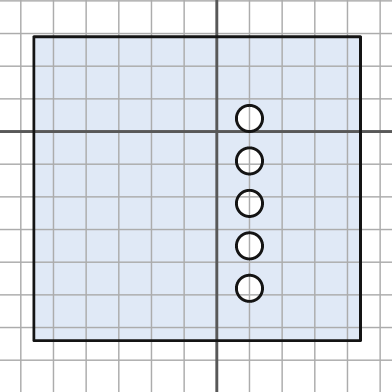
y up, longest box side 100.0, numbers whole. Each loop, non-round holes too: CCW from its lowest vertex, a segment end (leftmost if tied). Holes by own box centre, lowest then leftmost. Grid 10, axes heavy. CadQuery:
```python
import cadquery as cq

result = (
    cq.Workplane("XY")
    .moveTo(-56.0, -64.0)
    .lineTo(44.0, -64.0)
    .lineTo(44.0, 29.0)
    .lineTo(-56.0, 29.0)
    .close()
    .moveTo(10.0, -48.0)
    .circle(4.0)
    .moveTo(10.0, -35.0)
    .circle(4.0)
    .moveTo(10.0, -22.0)
    .circle(4.0)
    .moveTo(10.0, -9.0)
    .circle(4.0)
    .moveTo(10.0, 4.0)
    .circle(4.0)
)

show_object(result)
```